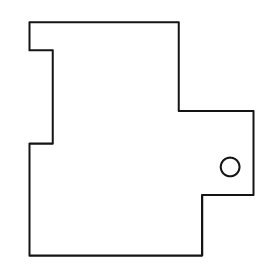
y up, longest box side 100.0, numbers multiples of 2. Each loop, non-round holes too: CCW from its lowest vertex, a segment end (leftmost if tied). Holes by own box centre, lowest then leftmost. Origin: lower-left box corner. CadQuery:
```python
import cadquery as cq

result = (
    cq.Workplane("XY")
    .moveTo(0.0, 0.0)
    .lineTo(74.0, 0.0)
    .lineTo(74.0, 26.0)
    .lineTo(96.0, 26.0)
    .lineTo(96.0, 62.0)
    .lineTo(64.0, 62.0)
    .lineTo(64.0, 100.0)
    .lineTo(0.0, 100.0)
    .lineTo(0.0, 88.0)
    .lineTo(10.0, 88.0)
    .lineTo(10.0, 48.0)
    .lineTo(0.0, 48.0)
    .close()
    .moveTo(86.0, 38.0)
    .circle(4.0)
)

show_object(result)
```